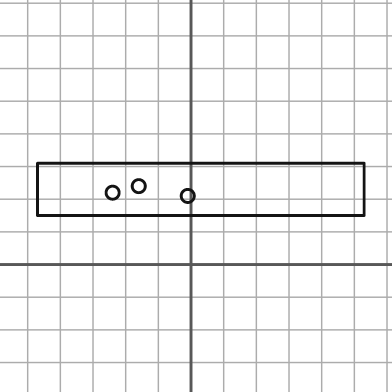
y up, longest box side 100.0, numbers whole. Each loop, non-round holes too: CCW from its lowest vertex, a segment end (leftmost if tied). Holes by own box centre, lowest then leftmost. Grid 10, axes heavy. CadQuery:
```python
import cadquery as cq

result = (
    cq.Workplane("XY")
    .moveTo(-47.0, 15.0)
    .lineTo(53.0, 15.0)
    .lineTo(53.0, 31.0)
    .lineTo(-47.0, 31.0)
    .close()
    .moveTo(-1.0, 21.0)
    .circle(2.0)
    .moveTo(-24.0, 22.0)
    .circle(2.0)
    .moveTo(-16.0, 24.0)
    .circle(2.0)
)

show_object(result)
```